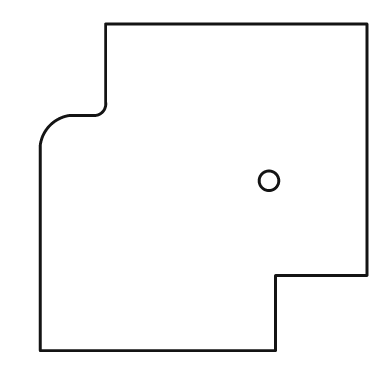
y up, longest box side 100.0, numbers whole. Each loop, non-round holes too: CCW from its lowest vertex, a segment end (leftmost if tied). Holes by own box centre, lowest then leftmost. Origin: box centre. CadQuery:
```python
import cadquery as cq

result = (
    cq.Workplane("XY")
    .moveTo(-50.0, -50.0)
    .lineTo(22.0, -50.0)
    .lineTo(22.0, -27.0)
    .lineTo(50.0, -27.0)
    .lineTo(50.0, 50.0)
    .lineTo(-30.0, 50.0)
    .lineTo(-30.0, 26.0)
    .threePointArc((-31.0, 23.0), (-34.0, 22.0))
    .lineTo(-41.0, 22.0)
    .threePointArc((-47.0, 19.0), (-50.0, 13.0))
    .close()
    .moveTo(20.0, 2.0)
    .circle(3.0)
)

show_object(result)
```